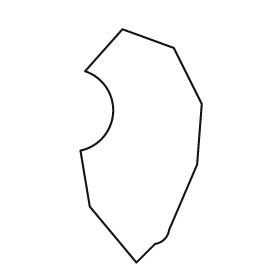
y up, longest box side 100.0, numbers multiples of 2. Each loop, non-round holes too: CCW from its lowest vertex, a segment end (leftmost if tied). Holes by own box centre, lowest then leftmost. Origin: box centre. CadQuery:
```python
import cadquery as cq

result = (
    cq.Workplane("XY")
    .moveTo(-2.0, -50.0)
    .lineTo(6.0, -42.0)
    .threePointArc((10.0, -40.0), (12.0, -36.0))
    .lineTo(24.0, -8.0)
    .lineTo(26.0, 18.0)
    .lineTo(14.0, 42.0)
    .lineTo(-8.0, 50.0)
    .lineTo(-24.0, 32.0)
    .threePointArc((-12.0, 14.0), (-26.0, -2.0))
    .lineTo(-22.0, -26.0)
    .close()
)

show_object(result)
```